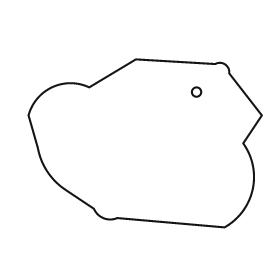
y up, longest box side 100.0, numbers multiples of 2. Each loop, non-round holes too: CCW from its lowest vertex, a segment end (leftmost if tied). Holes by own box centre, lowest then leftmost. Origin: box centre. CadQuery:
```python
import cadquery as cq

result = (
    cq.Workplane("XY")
    .moveTo(34.0, -36.0)
    .threePointArc((46.0, -20.0), (42.0, 0.0))
    .lineTo(50.0, 12.0)
    .lineTo(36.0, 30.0)
    .threePointArc((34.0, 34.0), (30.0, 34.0))
    .lineTo(-4.0, 36.0)
    .lineTo(-24.0, 24.0)
    .threePointArc((-40.0, 24.0), (-50.0, 12.0))
    .lineTo(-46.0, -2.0)
    .threePointArc((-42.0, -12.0), (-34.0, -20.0))
    .lineTo(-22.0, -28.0)
    .threePointArc((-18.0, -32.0), (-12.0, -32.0))
    .close()
    .moveTo(22.0, 22.0)
    .circle(2.0)
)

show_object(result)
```